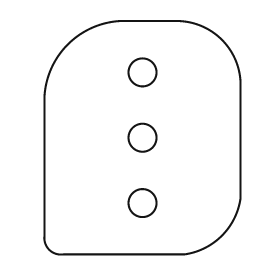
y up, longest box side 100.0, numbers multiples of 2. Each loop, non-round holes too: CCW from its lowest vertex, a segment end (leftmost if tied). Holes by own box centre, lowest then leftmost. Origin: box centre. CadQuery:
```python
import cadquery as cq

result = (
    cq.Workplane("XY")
    .moveTo(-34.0, -50.0)
    .lineTo(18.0, -50.0)
    .threePointArc((34.0, -42.0), (42.0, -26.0))
    .lineTo(42.0, 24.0)
    .threePointArc((34.0, 42.0), (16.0, 50.0))
    .lineTo(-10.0, 50.0)
    .threePointArc((-32.0, 40.0), (-42.0, 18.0))
    .lineTo(-42.0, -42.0)
    .threePointArc((-40.0, -48.0), (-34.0, -50.0))
    .close()
    .moveTo(0.0, -28.0)
    .circle(6.0)
    .moveTo(0.0, 0.0)
    .circle(6.0)
    .moveTo(0.0, 28.0)
    .circle(6.0)
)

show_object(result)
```